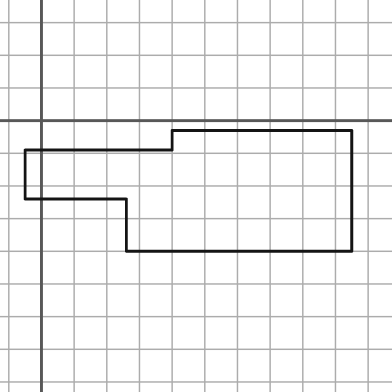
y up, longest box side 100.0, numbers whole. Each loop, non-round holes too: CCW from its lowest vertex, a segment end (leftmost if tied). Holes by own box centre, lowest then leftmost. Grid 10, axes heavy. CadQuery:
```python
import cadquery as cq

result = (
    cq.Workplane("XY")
    .moveTo(26.0, -40.0)
    .lineTo(95.0, -40.0)
    .lineTo(95.0, -3.0)
    .lineTo(40.0, -3.0)
    .lineTo(40.0, -9.0)
    .lineTo(-5.0, -9.0)
    .lineTo(-5.0, -24.0)
    .lineTo(26.0, -24.0)
    .close()
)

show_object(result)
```